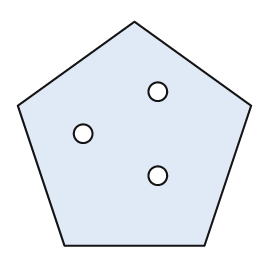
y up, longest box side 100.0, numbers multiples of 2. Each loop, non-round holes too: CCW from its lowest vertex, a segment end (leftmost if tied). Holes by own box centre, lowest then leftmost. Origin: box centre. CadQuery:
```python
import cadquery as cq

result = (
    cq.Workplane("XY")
    .moveTo(-30.0, -48.0)
    .lineTo(30.0, -48.0)
    .lineTo(50.0, 12.0)
    .lineTo(0.0, 48.0)
    .lineTo(-50.0, 12.0)
    .close()
    .moveTo(10.0, -18.0)
    .circle(4.0)
    .moveTo(-22.0, 0.0)
    .circle(4.0)
    .moveTo(10.0, 18.0)
    .circle(4.0)
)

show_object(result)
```